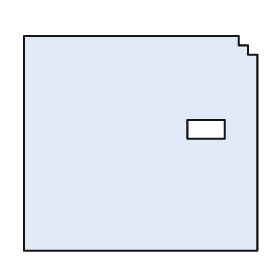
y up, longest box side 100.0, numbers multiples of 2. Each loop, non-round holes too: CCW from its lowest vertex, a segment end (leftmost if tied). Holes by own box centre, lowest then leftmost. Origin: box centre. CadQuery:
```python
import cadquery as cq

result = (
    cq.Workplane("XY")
    .moveTo(-50.0, -46.0)
    .lineTo(50.0, -46.0)
    .lineTo(50.0, 38.0)
    .lineTo(46.0, 38.0)
    .lineTo(46.0, 42.0)
    .lineTo(42.0, 42.0)
    .lineTo(42.0, 46.0)
    .lineTo(-50.0, 46.0)
    .close()
    .moveTo(20.0, 2.0)
    .lineTo(36.0, 2.0)
    .lineTo(36.0, 10.0)
    .lineTo(20.0, 10.0)
    .close()
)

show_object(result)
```